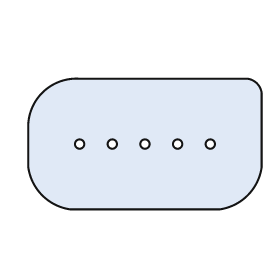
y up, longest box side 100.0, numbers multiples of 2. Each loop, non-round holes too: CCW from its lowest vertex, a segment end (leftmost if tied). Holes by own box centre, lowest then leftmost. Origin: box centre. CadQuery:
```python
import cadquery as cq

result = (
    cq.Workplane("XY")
    .moveTo(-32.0, -28.0)
    .lineTo(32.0, -28.0)
    .threePointArc((44.0, -22.0), (50.0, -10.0))
    .lineTo(50.0, 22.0)
    .threePointArc((48.0, 26.0), (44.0, 28.0))
    .lineTo(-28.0, 28.0)
    .threePointArc((-44.0, 22.0), (-50.0, 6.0))
    .lineTo(-50.0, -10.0)
    .threePointArc((-44.0, -22.0), (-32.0, -28.0))
    .close()
    .moveTo(-28.0, 0.0)
    .circle(2.0)
    .moveTo(-14.0, 0.0)
    .circle(2.0)
    .moveTo(0.0, 0.0)
    .circle(2.0)
    .moveTo(14.0, 0.0)
    .circle(2.0)
    .moveTo(28.0, 0.0)
    .circle(2.0)
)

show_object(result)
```